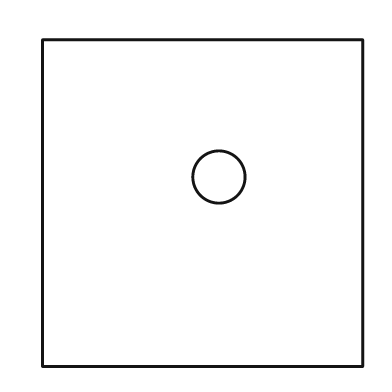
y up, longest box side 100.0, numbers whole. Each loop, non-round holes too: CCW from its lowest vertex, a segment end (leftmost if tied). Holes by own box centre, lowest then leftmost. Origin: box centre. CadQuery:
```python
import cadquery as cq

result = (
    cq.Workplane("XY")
    .moveTo(-49.0, -50.0)
    .lineTo(49.0, -50.0)
    .lineTo(49.0, 50.0)
    .lineTo(-49.0, 50.0)
    .close()
    .moveTo(5.0, 8.0)
    .circle(8.0)
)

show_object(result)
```